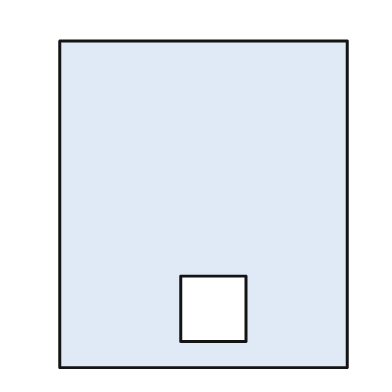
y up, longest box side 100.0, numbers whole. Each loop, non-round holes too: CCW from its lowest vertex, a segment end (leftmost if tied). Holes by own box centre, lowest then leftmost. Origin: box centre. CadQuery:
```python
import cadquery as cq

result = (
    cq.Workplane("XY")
    .moveTo(-44.0, -50.0)
    .lineTo(44.0, -50.0)
    .lineTo(44.0, 50.0)
    .lineTo(-44.0, 50.0)
    .close()
    .moveTo(-7.0, -42.0)
    .lineTo(13.0, -42.0)
    .lineTo(13.0, -22.0)
    .lineTo(-7.0, -22.0)
    .close()
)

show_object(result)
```